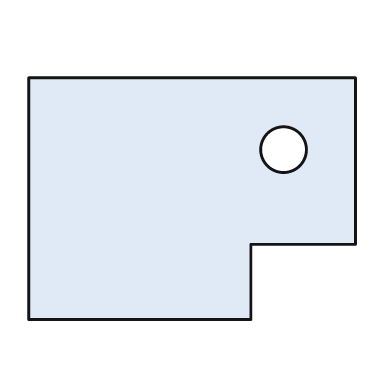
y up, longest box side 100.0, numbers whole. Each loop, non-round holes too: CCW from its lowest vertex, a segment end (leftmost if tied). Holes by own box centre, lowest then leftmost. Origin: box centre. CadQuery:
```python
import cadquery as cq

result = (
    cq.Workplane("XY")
    .moveTo(-50.0, -37.0)
    .lineTo(18.0, -37.0)
    .lineTo(18.0, -14.0)
    .lineTo(50.0, -14.0)
    .lineTo(50.0, 37.0)
    .lineTo(-50.0, 37.0)
    .close()
    .moveTo(28.0, 15.0)
    .circle(7.0)
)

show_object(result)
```